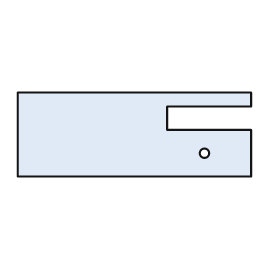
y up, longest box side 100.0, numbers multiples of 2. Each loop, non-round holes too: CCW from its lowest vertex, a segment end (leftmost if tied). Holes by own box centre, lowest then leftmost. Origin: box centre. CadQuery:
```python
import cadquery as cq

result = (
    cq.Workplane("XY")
    .moveTo(-50.0, -18.0)
    .lineTo(50.0, -18.0)
    .lineTo(50.0, 2.0)
    .lineTo(14.0, 2.0)
    .lineTo(14.0, 12.0)
    .lineTo(50.0, 12.0)
    .lineTo(50.0, 18.0)
    .lineTo(-50.0, 18.0)
    .close()
    .moveTo(30.0, -8.0)
    .circle(2.0)
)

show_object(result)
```